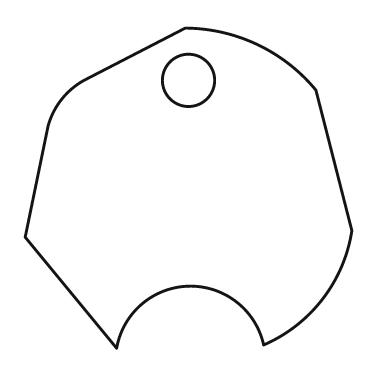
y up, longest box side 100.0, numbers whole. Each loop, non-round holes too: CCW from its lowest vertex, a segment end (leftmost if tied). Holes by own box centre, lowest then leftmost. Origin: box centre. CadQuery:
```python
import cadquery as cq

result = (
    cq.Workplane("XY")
    .moveTo(-22.0, -49.0)
    .threePointArc((0.0, -30.0), (23.0, -48.0))
    .threePointArc((41.0, -34.0), (50.0, -13.0))
    .lineTo(39.0, 30.0)
    .threePointArc((21.0, 44.0), (-1.0, 49.0))
    .lineTo(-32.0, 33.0)
    .threePointArc((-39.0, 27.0), (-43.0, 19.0))
    .lineTo(-50.0, -15.0)
    .close()
    .moveTo(0.0, 33.0)
    .circle(8.0)
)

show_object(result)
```